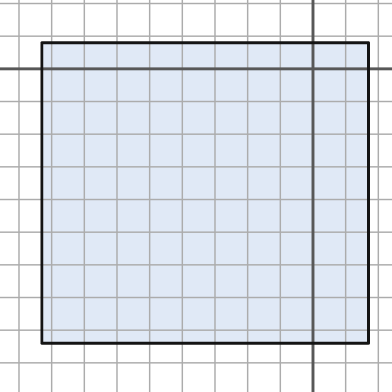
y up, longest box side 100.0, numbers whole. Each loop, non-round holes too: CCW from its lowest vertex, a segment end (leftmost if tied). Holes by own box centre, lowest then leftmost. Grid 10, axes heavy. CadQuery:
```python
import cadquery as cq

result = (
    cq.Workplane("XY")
    .moveTo(-83.0, -84.0)
    .lineTo(17.0, -84.0)
    .lineTo(17.0, 8.0)
    .lineTo(-83.0, 8.0)
    .close()
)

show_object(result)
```